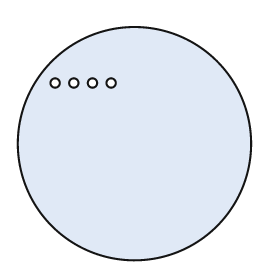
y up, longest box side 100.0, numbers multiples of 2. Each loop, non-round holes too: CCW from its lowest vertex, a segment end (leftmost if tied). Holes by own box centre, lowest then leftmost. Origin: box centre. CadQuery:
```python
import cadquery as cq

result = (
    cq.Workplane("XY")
    .moveTo(0.0, 0.0)
    .circle(50.0)
    .moveTo(-34.0, 26.0)
    .circle(2.0)
    .moveTo(-26.0, 26.0)
    .circle(2.0)
    .moveTo(-18.0, 26.0)
    .circle(2.0)
    .moveTo(-10.0, 26.0)
    .circle(2.0)
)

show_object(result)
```